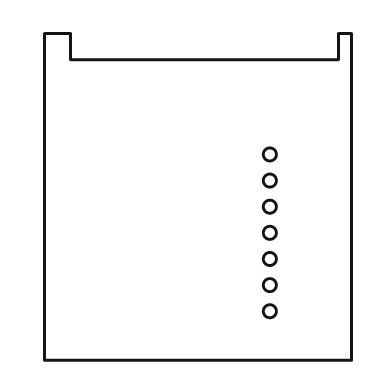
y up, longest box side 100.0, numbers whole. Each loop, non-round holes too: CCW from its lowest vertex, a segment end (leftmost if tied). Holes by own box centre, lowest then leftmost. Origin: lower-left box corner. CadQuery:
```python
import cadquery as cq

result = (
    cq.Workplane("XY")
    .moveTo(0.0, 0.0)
    .lineTo(94.0, 0.0)
    .lineTo(94.0, 100.0)
    .lineTo(90.0, 100.0)
    .lineTo(90.0, 92.0)
    .lineTo(8.0, 92.0)
    .lineTo(8.0, 100.0)
    .lineTo(0.0, 100.0)
    .close()
    .moveTo(69.0, 15.0)
    .circle(2.0)
    .moveTo(69.0, 23.0)
    .circle(2.0)
    .moveTo(69.0, 31.0)
    .circle(2.0)
    .moveTo(69.0, 39.0)
    .circle(2.0)
    .moveTo(69.0, 47.0)
    .circle(2.0)
    .moveTo(69.0, 55.0)
    .circle(2.0)
    .moveTo(69.0, 63.0)
    .circle(2.0)
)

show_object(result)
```